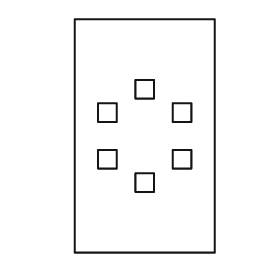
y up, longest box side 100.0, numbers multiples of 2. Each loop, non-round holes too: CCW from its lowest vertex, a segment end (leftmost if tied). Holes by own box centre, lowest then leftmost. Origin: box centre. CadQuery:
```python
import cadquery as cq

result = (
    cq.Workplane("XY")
    .moveTo(-30.0, -50.0)
    .lineTo(30.0, -50.0)
    .lineTo(30.0, 50.0)
    .lineTo(-30.0, 50.0)
    .close()
    .moveTo(-4.0, -24.0)
    .lineTo(4.0, -24.0)
    .lineTo(4.0, -16.0)
    .lineTo(-4.0, -16.0)
    .close()
    .moveTo(-20.0, -14.0)
    .lineTo(-12.0, -14.0)
    .lineTo(-12.0, -6.0)
    .lineTo(-20.0, -6.0)
    .close()
    .moveTo(12.0, -14.0)
    .lineTo(20.0, -14.0)
    .lineTo(20.0, -6.0)
    .lineTo(12.0, -6.0)
    .close()
    .moveTo(-20.0, 6.0)
    .lineTo(-12.0, 6.0)
    .lineTo(-12.0, 14.0)
    .lineTo(-20.0, 14.0)
    .close()
    .moveTo(12.0, 6.0)
    .lineTo(20.0, 6.0)
    .lineTo(20.0, 14.0)
    .lineTo(12.0, 14.0)
    .close()
    .moveTo(-4.0, 16.0)
    .lineTo(4.0, 16.0)
    .lineTo(4.0, 24.0)
    .lineTo(-4.0, 24.0)
    .close()
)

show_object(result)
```